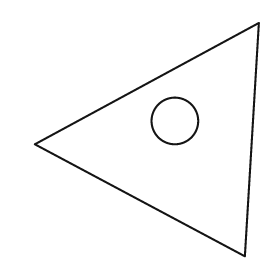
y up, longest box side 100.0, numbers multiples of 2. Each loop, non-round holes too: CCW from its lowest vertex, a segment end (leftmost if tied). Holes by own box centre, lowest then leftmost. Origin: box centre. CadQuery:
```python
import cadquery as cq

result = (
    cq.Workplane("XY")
    .moveTo(42.0, -50.0)
    .lineTo(48.0, 50.0)
    .lineTo(-48.0, -2.0)
    .close()
    .moveTo(12.0, 8.0)
    .circle(10.0)
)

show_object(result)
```